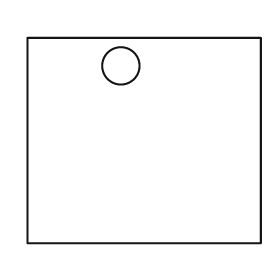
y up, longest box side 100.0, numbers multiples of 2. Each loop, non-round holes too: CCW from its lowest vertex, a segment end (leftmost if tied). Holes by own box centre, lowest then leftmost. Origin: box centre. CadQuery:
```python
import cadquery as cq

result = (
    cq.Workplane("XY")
    .moveTo(-50.0, -44.0)
    .lineTo(50.0, -44.0)
    .lineTo(50.0, 44.0)
    .lineTo(-50.0, 44.0)
    .close()
    .moveTo(-10.0, 32.0)
    .circle(8.0)
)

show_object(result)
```